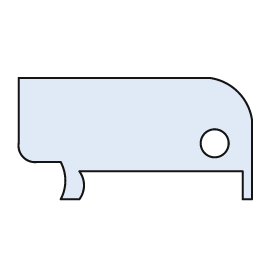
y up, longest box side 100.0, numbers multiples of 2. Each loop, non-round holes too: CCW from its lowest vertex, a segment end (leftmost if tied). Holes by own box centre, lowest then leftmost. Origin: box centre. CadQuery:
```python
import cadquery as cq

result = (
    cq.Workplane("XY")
    .moveTo(-32.0, -26.0)
    .lineTo(-24.0, -26.0)
    .threePointArc((-22.0, -20.0), (-24.0, -14.0))
    .lineTo(46.0, -14.0)
    .lineTo(46.0, -26.0)
    .lineTo(50.0, -26.0)
    .lineTo(50.0, 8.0)
    .threePointArc((44.0, 20.0), (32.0, 26.0))
    .lineTo(-50.0, 26.0)
    .lineTo(-50.0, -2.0)
    .threePointArc((-48.0, -8.0), (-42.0, -10.0))
    .lineTo(-32.0, -10.0)
    .threePointArc((-30.0, -18.0), (-32.0, -26.0))
    .close()
    .moveTo(34.0, -2.0)
    .circle(6.0)
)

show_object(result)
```